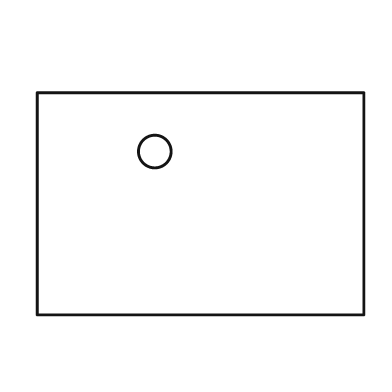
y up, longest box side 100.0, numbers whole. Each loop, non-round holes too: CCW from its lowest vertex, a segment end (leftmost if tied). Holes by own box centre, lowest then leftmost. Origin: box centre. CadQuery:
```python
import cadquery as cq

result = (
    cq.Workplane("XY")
    .moveTo(-50.0, -34.0)
    .lineTo(50.0, -34.0)
    .lineTo(50.0, 34.0)
    .lineTo(-50.0, 34.0)
    .close()
    .moveTo(-14.0, 16.0)
    .circle(5.0)
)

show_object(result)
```